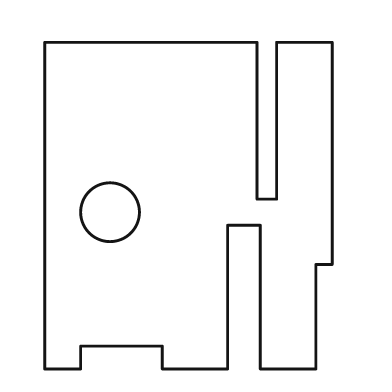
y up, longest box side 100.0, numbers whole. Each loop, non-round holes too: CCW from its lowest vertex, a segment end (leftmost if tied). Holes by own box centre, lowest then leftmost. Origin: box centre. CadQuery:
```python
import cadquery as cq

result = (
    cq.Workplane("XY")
    .moveTo(-44.0, -50.0)
    .lineTo(-33.0, -50.0)
    .lineTo(-33.0, -43.0)
    .lineTo(-8.0, -43.0)
    .lineTo(-8.0, -50.0)
    .lineTo(12.0, -50.0)
    .lineTo(12.0, -6.0)
    .lineTo(22.0, -6.0)
    .lineTo(22.0, -50.0)
    .lineTo(39.0, -50.0)
    .lineTo(39.0, -18.0)
    .lineTo(44.0, -18.0)
    .lineTo(44.0, 50.0)
    .lineTo(27.0, 50.0)
    .lineTo(27.0, 2.0)
    .lineTo(21.0, 2.0)
    .lineTo(21.0, 50.0)
    .lineTo(-44.0, 50.0)
    .close()
    .moveTo(-24.0, -2.0)
    .circle(9.0)
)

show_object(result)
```